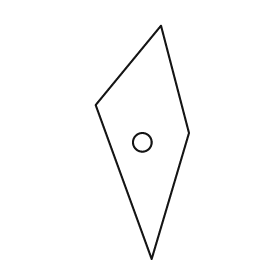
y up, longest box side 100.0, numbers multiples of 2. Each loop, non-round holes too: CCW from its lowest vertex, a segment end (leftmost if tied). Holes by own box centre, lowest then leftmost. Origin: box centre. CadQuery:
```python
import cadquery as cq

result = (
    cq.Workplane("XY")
    .moveTo(4.0, -50.0)
    .lineTo(20.0, 4.0)
    .lineTo(8.0, 50.0)
    .lineTo(-20.0, 16.0)
    .close()
    .moveTo(0.0, 0.0)
    .circle(4.0)
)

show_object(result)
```